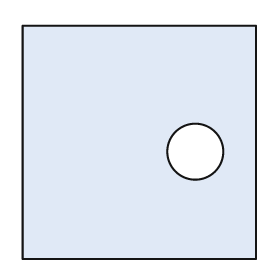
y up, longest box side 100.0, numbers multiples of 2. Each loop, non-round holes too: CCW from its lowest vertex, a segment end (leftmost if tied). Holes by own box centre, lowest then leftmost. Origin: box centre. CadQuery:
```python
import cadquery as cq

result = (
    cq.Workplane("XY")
    .moveTo(-50.0, -50.0)
    .lineTo(50.0, -50.0)
    .lineTo(50.0, 50.0)
    .lineTo(-50.0, 50.0)
    .close()
    .moveTo(24.0, -4.0)
    .circle(12.0)
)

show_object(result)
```